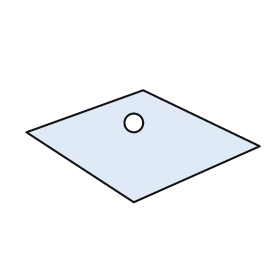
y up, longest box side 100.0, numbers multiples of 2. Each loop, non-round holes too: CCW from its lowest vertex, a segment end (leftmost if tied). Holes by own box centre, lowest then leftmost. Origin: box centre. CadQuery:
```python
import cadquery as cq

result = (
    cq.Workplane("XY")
    .moveTo(-4.0, -24.0)
    .lineTo(50.0, 0.0)
    .lineTo(0.0, 24.0)
    .lineTo(-50.0, 6.0)
    .close()
    .moveTo(-4.0, 10.0)
    .circle(4.0)
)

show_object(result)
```